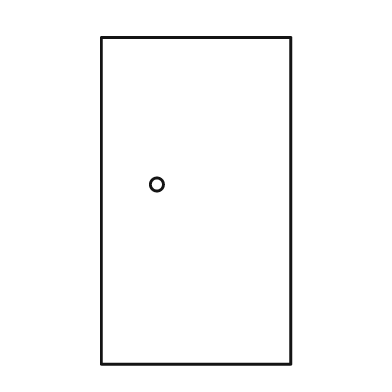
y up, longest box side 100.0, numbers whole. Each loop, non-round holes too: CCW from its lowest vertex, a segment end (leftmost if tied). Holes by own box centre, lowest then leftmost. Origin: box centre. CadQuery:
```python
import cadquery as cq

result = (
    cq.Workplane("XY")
    .moveTo(-29.0, -50.0)
    .lineTo(29.0, -50.0)
    .lineTo(29.0, 50.0)
    .lineTo(-29.0, 50.0)
    .close()
    .moveTo(-12.0, 5.0)
    .circle(2.0)
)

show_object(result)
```